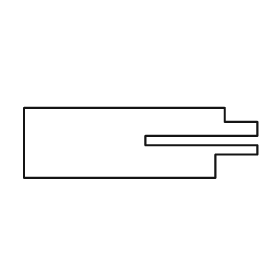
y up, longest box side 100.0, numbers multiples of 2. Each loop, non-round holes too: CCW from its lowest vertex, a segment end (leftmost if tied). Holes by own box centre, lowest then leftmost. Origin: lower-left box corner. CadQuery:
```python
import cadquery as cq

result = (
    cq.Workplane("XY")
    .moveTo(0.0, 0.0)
    .lineTo(82.0, 0.0)
    .lineTo(82.0, 10.0)
    .lineTo(100.0, 10.0)
    .lineTo(100.0, 14.0)
    .lineTo(52.0, 14.0)
    .lineTo(52.0, 18.0)
    .lineTo(100.0, 18.0)
    .lineTo(100.0, 24.0)
    .lineTo(86.0, 24.0)
    .lineTo(86.0, 30.0)
    .lineTo(0.0, 30.0)
    .close()
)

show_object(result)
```